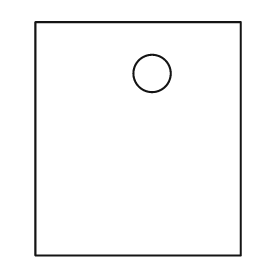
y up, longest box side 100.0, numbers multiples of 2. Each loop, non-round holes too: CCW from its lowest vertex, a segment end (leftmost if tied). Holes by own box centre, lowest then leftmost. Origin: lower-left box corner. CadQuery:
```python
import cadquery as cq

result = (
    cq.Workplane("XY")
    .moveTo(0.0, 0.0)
    .lineTo(88.0, 0.0)
    .lineTo(88.0, 100.0)
    .lineTo(0.0, 100.0)
    .close()
    .moveTo(50.0, 78.0)
    .circle(8.0)
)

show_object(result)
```